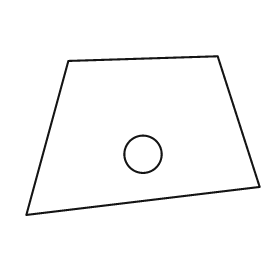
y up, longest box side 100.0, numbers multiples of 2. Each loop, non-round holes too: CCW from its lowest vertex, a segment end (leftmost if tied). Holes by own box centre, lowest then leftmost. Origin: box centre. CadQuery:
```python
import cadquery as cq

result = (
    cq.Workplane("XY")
    .moveTo(-50.0, -34.0)
    .lineTo(50.0, -22.0)
    .lineTo(32.0, 34.0)
    .lineTo(-32.0, 32.0)
    .close()
    .moveTo(0.0, -8.0)
    .circle(8.0)
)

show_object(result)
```